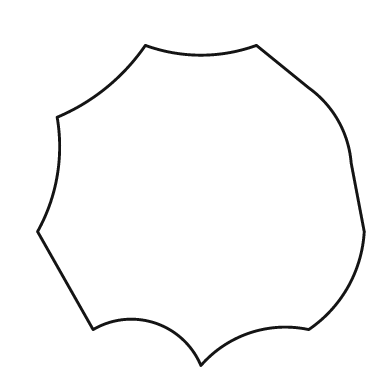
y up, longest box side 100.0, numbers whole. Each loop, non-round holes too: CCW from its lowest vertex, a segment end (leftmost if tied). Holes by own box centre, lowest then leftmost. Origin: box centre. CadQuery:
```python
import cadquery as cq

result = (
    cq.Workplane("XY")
    .moveTo(0.0, -49.0)
    .threePointArc((15.0, -39.0), (33.0, -38.0))
    .threePointArc((45.0, -25.0), (50.0, -8.0))
    .lineTo(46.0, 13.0)
    .threePointArc((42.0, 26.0), (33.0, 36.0))
    .lineTo(17.0, 49.0)
    .threePointArc((0.0, 46.0), (-17.0, 49.0))
    .threePointArc((-29.0, 36.0), (-44.0, 27.0))
    .threePointArc((-44.0, 9.0), (-50.0, -8.0))
    .lineTo(-33.0, -38.0)
    .threePointArc((-14.0, -36.0), (0.0, -49.0))
    .close()
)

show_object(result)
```